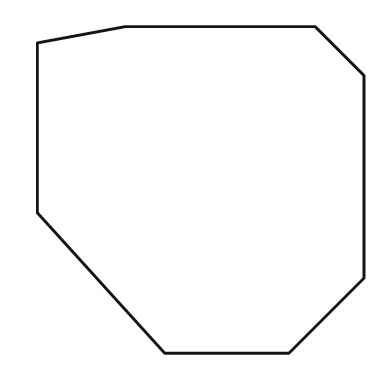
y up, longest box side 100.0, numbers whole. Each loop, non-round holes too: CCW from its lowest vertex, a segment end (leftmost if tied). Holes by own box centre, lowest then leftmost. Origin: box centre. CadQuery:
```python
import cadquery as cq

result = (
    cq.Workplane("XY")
    .moveTo(-11.0, -50.0)
    .lineTo(27.0, -50.0)
    .lineTo(50.0, -27.0)
    .lineTo(50.0, 35.0)
    .lineTo(35.0, 50.0)
    .lineTo(-23.0, 50.0)
    .lineTo(-50.0, 45.0)
    .lineTo(-50.0, -7.0)
    .close()
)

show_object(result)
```